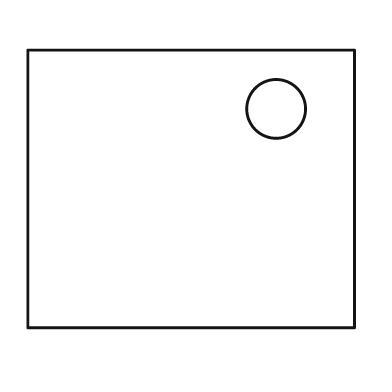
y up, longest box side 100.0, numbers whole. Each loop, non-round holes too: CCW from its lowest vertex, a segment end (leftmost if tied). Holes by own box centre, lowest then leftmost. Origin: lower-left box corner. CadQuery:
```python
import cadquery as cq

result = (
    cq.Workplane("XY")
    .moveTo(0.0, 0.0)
    .lineTo(100.0, 0.0)
    .lineTo(100.0, 85.0)
    .lineTo(0.0, 85.0)
    .close()
    .moveTo(76.0, 67.0)
    .circle(9.0)
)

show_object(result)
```